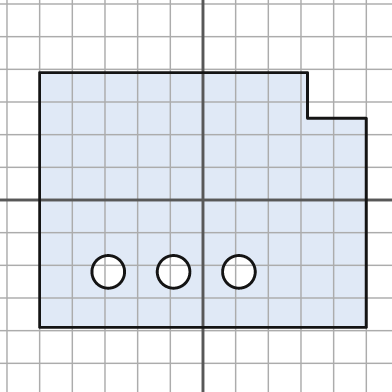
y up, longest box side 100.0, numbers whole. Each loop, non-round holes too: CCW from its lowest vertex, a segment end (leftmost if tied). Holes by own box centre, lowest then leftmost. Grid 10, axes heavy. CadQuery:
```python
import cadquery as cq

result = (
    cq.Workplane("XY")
    .moveTo(-50.0, -39.0)
    .lineTo(50.0, -39.0)
    .lineTo(50.0, 25.0)
    .lineTo(32.0, 25.0)
    .lineTo(32.0, 39.0)
    .lineTo(-50.0, 39.0)
    .close()
    .moveTo(-29.0, -22.0)
    .circle(5.0)
    .moveTo(-9.0, -22.0)
    .circle(5.0)
    .moveTo(11.0, -22.0)
    .circle(5.0)
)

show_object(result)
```